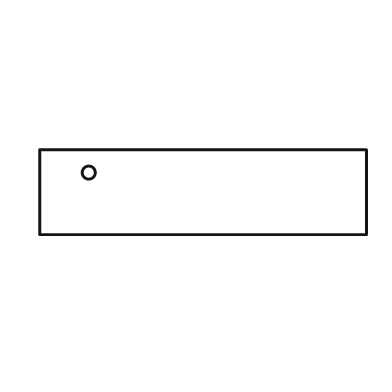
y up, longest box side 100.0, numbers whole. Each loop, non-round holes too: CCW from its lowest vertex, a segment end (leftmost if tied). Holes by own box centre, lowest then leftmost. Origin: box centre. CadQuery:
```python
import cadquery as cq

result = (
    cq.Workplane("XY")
    .moveTo(-50.0, -13.0)
    .lineTo(50.0, -13.0)
    .lineTo(50.0, 13.0)
    .lineTo(-50.0, 13.0)
    .close()
    .moveTo(-35.0, 6.0)
    .circle(2.0)
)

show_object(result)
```